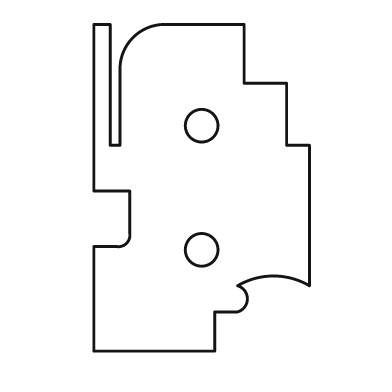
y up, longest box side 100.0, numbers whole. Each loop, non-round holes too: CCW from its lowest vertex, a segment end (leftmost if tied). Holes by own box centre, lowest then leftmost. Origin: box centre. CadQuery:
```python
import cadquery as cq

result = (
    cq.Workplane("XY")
    .moveTo(-33.0, -50.0)
    .lineTo(4.0, -50.0)
    .lineTo(4.0, -38.0)
    .lineTo(11.0, -38.0)
    .threePointArc((14.0, -34.0), (11.0, -30.0))
    .threePointArc((22.0, -27.0), (33.0, -30.0))
    .lineTo(33.0, 13.0)
    .lineTo(26.0, 13.0)
    .lineTo(26.0, 32.0)
    .lineTo(13.0, 32.0)
    .lineTo(13.0, 50.0)
    .lineTo(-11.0, 50.0)
    .threePointArc((-21.0, 46.0), (-25.0, 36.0))
    .lineTo(-25.0, 13.0)
    .lineTo(-28.0, 13.0)
    .lineTo(-28.0, 50.0)
    .lineTo(-33.0, 50.0)
    .lineTo(-33.0, -1.0)
    .lineTo(-22.0, -1.0)
    .lineTo(-22.0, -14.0)
    .threePointArc((-23.0, -17.0), (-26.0, -18.0))
    .lineTo(-33.0, -18.0)
    .close()
    .moveTo(0.0, -19.0)
    .circle(5.0)
    .moveTo(0.0, 19.0)
    .circle(5.0)
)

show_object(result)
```